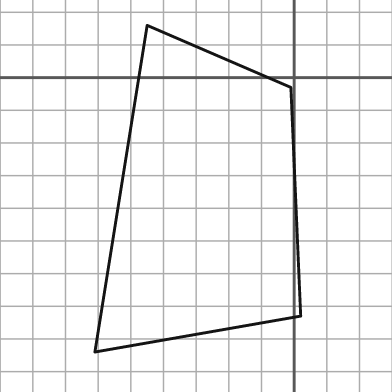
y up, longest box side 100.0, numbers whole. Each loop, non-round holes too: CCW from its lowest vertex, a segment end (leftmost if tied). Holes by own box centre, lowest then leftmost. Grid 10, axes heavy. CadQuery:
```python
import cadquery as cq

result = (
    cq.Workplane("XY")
    .moveTo(-61.0, -84.0)
    .lineTo(2.0, -73.0)
    .lineTo(-1.0, -3.0)
    .lineTo(-45.0, 16.0)
    .close()
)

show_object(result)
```